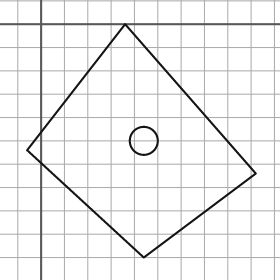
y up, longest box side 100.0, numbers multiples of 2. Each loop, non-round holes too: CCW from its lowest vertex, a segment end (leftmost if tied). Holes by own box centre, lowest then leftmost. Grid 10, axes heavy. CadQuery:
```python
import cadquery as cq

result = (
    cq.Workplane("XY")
    .moveTo(44.0, -100.0)
    .lineTo(92.0, -64.0)
    .lineTo(36.0, 0.0)
    .lineTo(-6.0, -54.0)
    .close()
    .moveTo(44.0, -50.0)
    .circle(6.0)
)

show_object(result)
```